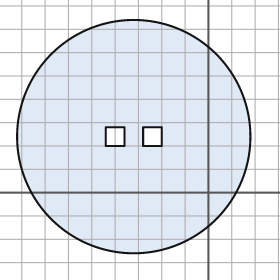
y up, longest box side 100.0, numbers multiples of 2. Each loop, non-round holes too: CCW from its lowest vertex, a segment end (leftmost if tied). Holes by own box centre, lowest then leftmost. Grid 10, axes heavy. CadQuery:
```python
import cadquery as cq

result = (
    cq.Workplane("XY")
    .moveTo(-32.0, 24.0)
    .circle(50.0)
    .moveTo(-44.0, 20.0)
    .lineTo(-36.0, 20.0)
    .lineTo(-36.0, 28.0)
    .lineTo(-44.0, 28.0)
    .close()
    .moveTo(-28.0, 20.0)
    .lineTo(-20.0, 20.0)
    .lineTo(-20.0, 28.0)
    .lineTo(-28.0, 28.0)
    .close()
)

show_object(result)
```